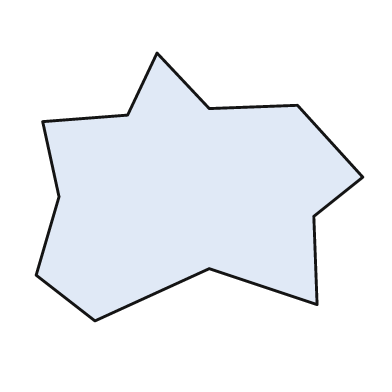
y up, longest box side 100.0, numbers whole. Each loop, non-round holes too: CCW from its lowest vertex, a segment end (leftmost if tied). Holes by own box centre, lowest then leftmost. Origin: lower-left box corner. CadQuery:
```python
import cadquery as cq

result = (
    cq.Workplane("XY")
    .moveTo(18.0, 0.0)
    .lineTo(53.0, 16.0)
    .lineTo(86.0, 5.0)
    .lineTo(85.0, 32.0)
    .lineTo(100.0, 44.0)
    .lineTo(80.0, 66.0)
    .lineTo(53.0, 65.0)
    .lineTo(37.0, 82.0)
    .lineTo(28.0, 63.0)
    .lineTo(2.0, 61.0)
    .lineTo(7.0, 38.0)
    .lineTo(0.0, 14.0)
    .close()
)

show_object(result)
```